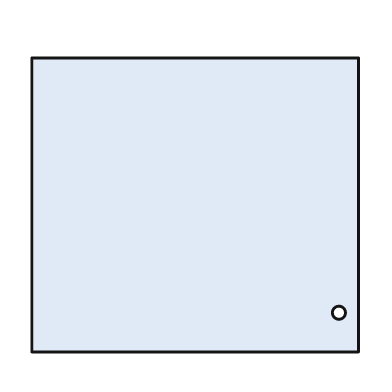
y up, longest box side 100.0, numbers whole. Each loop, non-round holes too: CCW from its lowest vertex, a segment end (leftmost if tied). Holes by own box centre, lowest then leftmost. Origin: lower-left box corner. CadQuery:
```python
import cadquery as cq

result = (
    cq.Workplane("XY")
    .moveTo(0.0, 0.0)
    .lineTo(100.0, 0.0)
    .lineTo(100.0, 90.0)
    .lineTo(0.0, 90.0)
    .close()
    .moveTo(94.0, 12.0)
    .circle(2.0)
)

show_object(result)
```